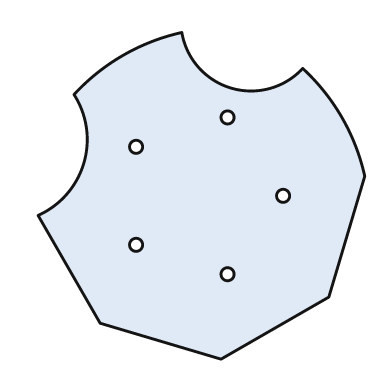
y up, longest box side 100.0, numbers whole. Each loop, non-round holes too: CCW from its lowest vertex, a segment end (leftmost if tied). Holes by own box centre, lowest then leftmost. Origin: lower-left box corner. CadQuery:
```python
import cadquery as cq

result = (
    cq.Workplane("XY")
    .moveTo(56.0, 0.0)
    .lineTo(89.0, 19.0)
    .lineTo(100.0, 56.0)
    .threePointArc((93.0, 74.0), (81.0, 89.0))
    .threePointArc((59.0, 83.0), (44.0, 100.0))
    .threePointArc((26.0, 93.0), (11.0, 81.0))
    .threePointArc((14.0, 60.0), (0.0, 44.0))
    .lineTo(19.0, 11.0)
    .close()
    .moveTo(58.0, 26.0)
    .circle(2.0)
    .moveTo(30.0, 35.0)
    .circle(2.0)
    .moveTo(75.0, 50.0)
    .circle(2.0)
    .moveTo(30.0, 65.0)
    .circle(2.0)
    .moveTo(58.0, 74.0)
    .circle(2.0)
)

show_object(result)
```